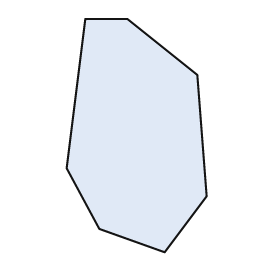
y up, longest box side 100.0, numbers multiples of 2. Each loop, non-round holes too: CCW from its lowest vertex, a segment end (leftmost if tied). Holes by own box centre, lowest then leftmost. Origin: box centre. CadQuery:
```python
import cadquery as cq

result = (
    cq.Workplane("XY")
    .moveTo(12.0, -50.0)
    .lineTo(30.0, -26.0)
    .lineTo(26.0, 26.0)
    .lineTo(-4.0, 50.0)
    .lineTo(-22.0, 50.0)
    .lineTo(-30.0, -14.0)
    .lineTo(-16.0, -40.0)
    .close()
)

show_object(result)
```